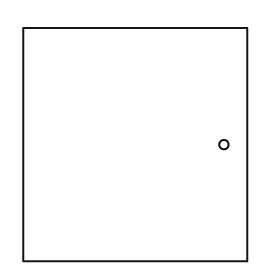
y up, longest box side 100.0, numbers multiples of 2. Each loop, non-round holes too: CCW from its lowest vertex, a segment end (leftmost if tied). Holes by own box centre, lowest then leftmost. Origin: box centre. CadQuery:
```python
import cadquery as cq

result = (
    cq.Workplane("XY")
    .moveTo(-48.0, -50.0)
    .lineTo(48.0, -50.0)
    .lineTo(48.0, 50.0)
    .lineTo(-48.0, 50.0)
    .close()
    .moveTo(38.0, 0.0)
    .circle(2.0)
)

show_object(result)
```